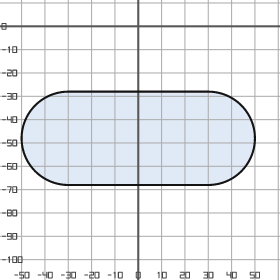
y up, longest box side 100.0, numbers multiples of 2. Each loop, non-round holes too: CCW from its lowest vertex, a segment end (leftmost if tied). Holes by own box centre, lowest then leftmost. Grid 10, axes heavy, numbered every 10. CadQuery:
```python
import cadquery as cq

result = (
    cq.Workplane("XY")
    .moveTo(-30.0, -68.0)
    .lineTo(30.0, -68.0)
    .threePointArc((50.0, -48.0), (30.0, -28.0))
    .lineTo(-30.0, -28.0)
    .threePointArc((-50.0, -48.0), (-30.0, -68.0))
    .close()
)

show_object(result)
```